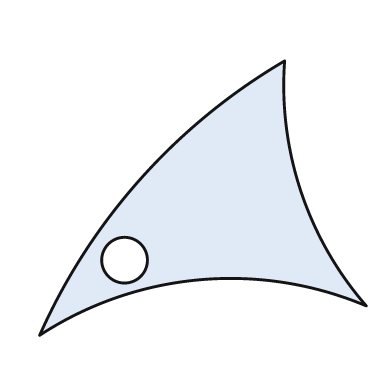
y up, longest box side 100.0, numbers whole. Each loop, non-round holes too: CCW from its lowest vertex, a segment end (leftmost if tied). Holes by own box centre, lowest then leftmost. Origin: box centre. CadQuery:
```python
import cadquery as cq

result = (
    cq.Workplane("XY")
    .moveTo(-50.0, -42.0)
    .threePointArc((-1.0, -25.0), (50.0, -33.0))
    .threePointArc((30.0, 2.0), (25.0, 42.0))
    .threePointArc((-19.0, 6.0), (-50.0, -42.0))
    .close()
    .moveTo(-24.0, -19.0)
    .circle(7.0)
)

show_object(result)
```